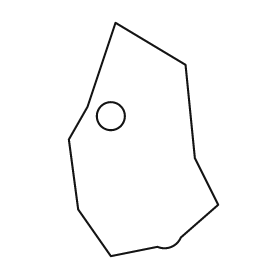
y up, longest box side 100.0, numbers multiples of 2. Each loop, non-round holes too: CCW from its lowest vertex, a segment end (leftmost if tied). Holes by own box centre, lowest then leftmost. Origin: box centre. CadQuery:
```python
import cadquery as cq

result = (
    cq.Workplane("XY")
    .moveTo(-14.0, -50.0)
    .lineTo(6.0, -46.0)
    .threePointArc((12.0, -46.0), (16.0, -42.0))
    .lineTo(32.0, -28.0)
    .lineTo(22.0, -8.0)
    .lineTo(18.0, 32.0)
    .lineTo(-12.0, 50.0)
    .lineTo(-24.0, 14.0)
    .lineTo(-32.0, 0.0)
    .lineTo(-28.0, -30.0)
    .close()
    .moveTo(-14.0, 10.0)
    .circle(6.0)
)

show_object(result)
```